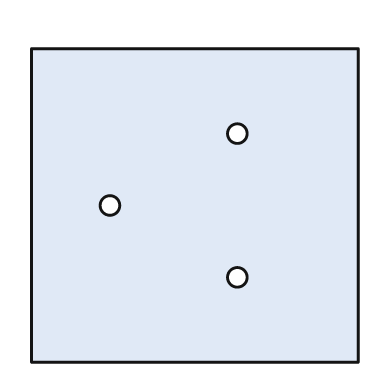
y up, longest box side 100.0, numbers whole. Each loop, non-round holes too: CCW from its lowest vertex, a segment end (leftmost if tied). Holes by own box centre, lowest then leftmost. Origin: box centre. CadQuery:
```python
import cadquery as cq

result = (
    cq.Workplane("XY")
    .moveTo(-50.0, -48.0)
    .lineTo(50.0, -48.0)
    .lineTo(50.0, 48.0)
    .lineTo(-50.0, 48.0)
    .close()
    .moveTo(13.0, -22.0)
    .circle(3.0)
    .moveTo(-26.0, 0.0)
    .circle(3.0)
    .moveTo(13.0, 22.0)
    .circle(3.0)
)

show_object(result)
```